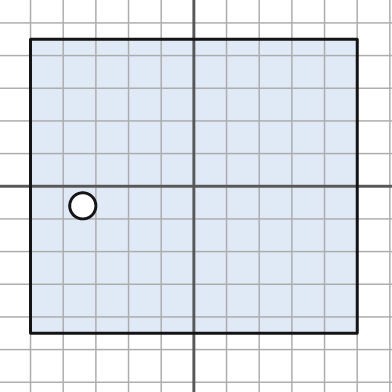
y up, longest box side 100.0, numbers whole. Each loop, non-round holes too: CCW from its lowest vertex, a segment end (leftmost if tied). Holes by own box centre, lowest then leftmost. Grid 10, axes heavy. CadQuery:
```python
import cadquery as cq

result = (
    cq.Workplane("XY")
    .moveTo(-50.0, -45.0)
    .lineTo(50.0, -45.0)
    .lineTo(50.0, 45.0)
    .lineTo(-50.0, 45.0)
    .close()
    .moveTo(-34.0, -6.0)
    .circle(4.0)
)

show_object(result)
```